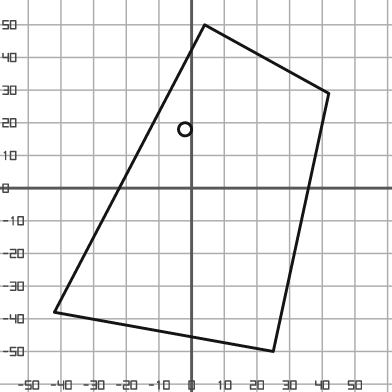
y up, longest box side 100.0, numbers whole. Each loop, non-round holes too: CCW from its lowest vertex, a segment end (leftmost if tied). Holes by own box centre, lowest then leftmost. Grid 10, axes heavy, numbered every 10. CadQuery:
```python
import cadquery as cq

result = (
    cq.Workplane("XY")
    .moveTo(25.0, -50.0)
    .lineTo(42.0, 29.0)
    .lineTo(4.0, 50.0)
    .lineTo(-42.0, -38.0)
    .close()
    .moveTo(-2.0, 18.0)
    .circle(2.0)
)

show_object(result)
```